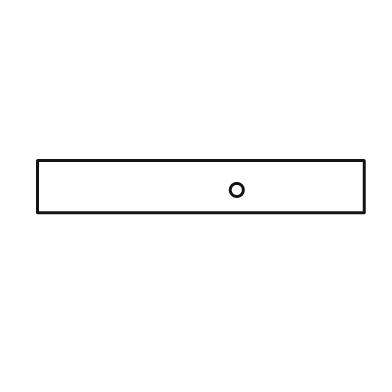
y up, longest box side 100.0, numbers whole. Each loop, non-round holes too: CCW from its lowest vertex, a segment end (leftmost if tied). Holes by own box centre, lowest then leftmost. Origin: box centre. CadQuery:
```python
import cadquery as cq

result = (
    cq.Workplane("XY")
    .moveTo(-50.0, -8.0)
    .lineTo(50.0, -8.0)
    .lineTo(50.0, 8.0)
    .lineTo(-50.0, 8.0)
    .close()
    .moveTo(11.0, -1.0)
    .circle(2.0)
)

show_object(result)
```